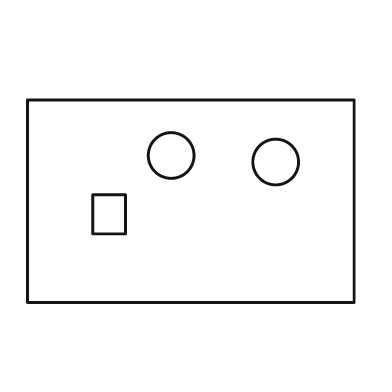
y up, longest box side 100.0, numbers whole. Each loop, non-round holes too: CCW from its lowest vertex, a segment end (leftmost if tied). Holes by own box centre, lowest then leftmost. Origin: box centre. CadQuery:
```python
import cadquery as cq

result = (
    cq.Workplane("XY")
    .moveTo(-50.0, -31.0)
    .lineTo(50.0, -31.0)
    .lineTo(50.0, 31.0)
    .lineTo(-50.0, 31.0)
    .close()
    .moveTo(-30.0, -10.0)
    .lineTo(-20.0, -10.0)
    .lineTo(-20.0, 2.0)
    .lineTo(-30.0, 2.0)
    .close()
    .moveTo(26.0, 12.0)
    .circle(7.0)
    .moveTo(-6.0, 14.0)
    .circle(7.0)
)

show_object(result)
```